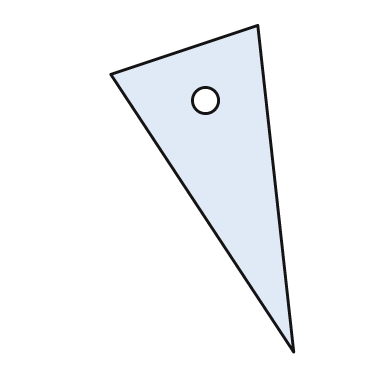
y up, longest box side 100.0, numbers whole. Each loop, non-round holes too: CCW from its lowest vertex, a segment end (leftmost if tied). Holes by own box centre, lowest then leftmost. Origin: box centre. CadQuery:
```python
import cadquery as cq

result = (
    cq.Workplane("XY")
    .moveTo(28.0, -50.0)
    .lineTo(17.0, 50.0)
    .lineTo(-28.0, 35.0)
    .close()
    .moveTo(1.0, 27.0)
    .circle(4.0)
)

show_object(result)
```